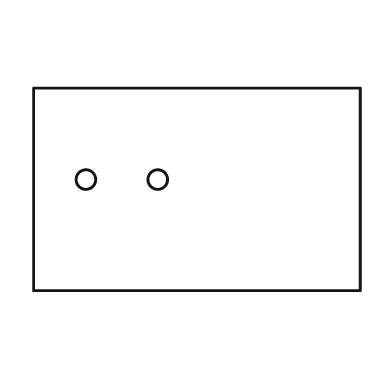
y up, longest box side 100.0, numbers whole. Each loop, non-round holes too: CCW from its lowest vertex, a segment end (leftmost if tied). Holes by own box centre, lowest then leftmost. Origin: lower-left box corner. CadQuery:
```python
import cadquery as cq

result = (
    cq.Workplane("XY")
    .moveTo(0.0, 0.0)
    .lineTo(100.0, 0.0)
    .lineTo(100.0, 62.0)
    .lineTo(0.0, 62.0)
    .close()
    .moveTo(16.0, 34.0)
    .circle(3.0)
    .moveTo(38.0, 34.0)
    .circle(3.0)
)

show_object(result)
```